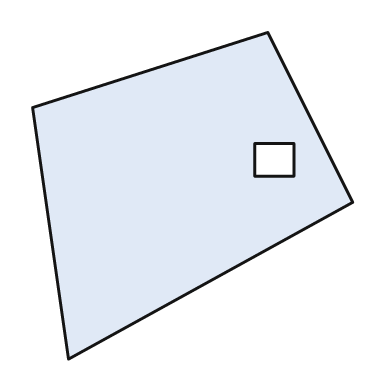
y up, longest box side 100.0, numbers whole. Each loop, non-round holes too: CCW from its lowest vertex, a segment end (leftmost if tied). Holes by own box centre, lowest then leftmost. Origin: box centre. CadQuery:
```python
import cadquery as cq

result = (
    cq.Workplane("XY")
    .moveTo(-38.0, -50.0)
    .lineTo(49.0, -2.0)
    .lineTo(23.0, 50.0)
    .lineTo(-49.0, 27.0)
    .close()
    .moveTo(19.0, 6.0)
    .lineTo(31.0, 6.0)
    .lineTo(31.0, 16.0)
    .lineTo(19.0, 16.0)
    .close()
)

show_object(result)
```